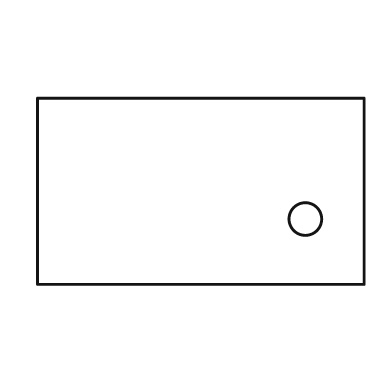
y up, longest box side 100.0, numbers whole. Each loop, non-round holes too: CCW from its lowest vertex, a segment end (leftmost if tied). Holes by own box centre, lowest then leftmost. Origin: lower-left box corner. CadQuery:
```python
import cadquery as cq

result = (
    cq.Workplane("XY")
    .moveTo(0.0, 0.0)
    .lineTo(100.0, 0.0)
    .lineTo(100.0, 57.0)
    .lineTo(0.0, 57.0)
    .close()
    .moveTo(82.0, 20.0)
    .circle(5.0)
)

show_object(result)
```